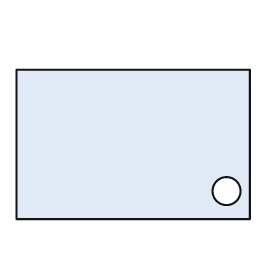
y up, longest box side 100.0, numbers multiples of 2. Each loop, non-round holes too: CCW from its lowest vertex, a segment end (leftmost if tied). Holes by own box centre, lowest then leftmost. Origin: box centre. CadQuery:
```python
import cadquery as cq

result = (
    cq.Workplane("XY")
    .moveTo(-50.0, -32.0)
    .lineTo(50.0, -32.0)
    .lineTo(50.0, 32.0)
    .lineTo(-50.0, 32.0)
    .close()
    .moveTo(40.0, -20.0)
    .circle(6.0)
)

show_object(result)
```